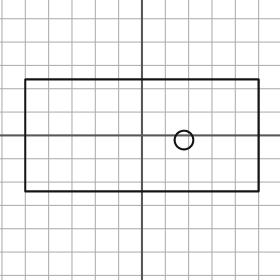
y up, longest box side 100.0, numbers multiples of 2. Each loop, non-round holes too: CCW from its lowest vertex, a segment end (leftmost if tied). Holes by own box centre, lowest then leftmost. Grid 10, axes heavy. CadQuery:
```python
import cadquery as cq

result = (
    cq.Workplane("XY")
    .moveTo(-50.0, -24.0)
    .lineTo(50.0, -24.0)
    .lineTo(50.0, 24.0)
    .lineTo(-50.0, 24.0)
    .close()
    .moveTo(18.0, -2.0)
    .circle(4.0)
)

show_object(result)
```